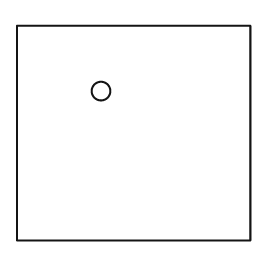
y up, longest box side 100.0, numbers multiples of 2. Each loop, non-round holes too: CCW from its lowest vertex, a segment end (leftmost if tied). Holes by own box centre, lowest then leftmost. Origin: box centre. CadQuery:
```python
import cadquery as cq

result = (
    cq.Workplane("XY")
    .moveTo(-50.0, -46.0)
    .lineTo(50.0, -46.0)
    .lineTo(50.0, 46.0)
    .lineTo(-50.0, 46.0)
    .close()
    .moveTo(-14.0, 18.0)
    .circle(4.0)
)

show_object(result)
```